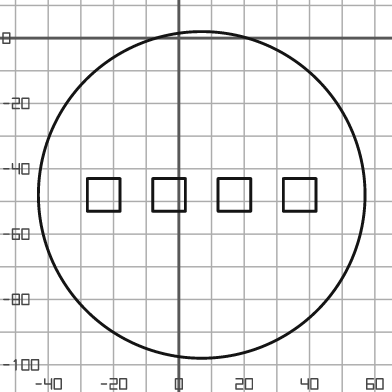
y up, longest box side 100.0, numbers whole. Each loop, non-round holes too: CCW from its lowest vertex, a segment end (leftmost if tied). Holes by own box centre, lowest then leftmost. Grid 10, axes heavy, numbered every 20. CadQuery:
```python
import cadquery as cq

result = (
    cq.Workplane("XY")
    .moveTo(7.0, -48.0)
    .circle(50.0)
    .moveTo(-28.0, -53.0)
    .lineTo(-18.0, -53.0)
    .lineTo(-18.0, -43.0)
    .lineTo(-28.0, -43.0)
    .close()
    .moveTo(-8.0, -53.0)
    .lineTo(2.0, -53.0)
    .lineTo(2.0, -43.0)
    .lineTo(-8.0, -43.0)
    .close()
    .moveTo(12.0, -53.0)
    .lineTo(22.0, -53.0)
    .lineTo(22.0, -43.0)
    .lineTo(12.0, -43.0)
    .close()
    .moveTo(32.0, -53.0)
    .lineTo(42.0, -53.0)
    .lineTo(42.0, -43.0)
    .lineTo(32.0, -43.0)
    .close()
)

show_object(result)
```